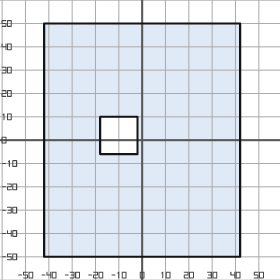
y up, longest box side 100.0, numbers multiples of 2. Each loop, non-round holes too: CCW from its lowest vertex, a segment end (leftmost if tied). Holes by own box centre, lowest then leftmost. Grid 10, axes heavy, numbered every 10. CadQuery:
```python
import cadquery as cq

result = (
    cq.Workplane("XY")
    .moveTo(-42.0, -50.0)
    .lineTo(42.0, -50.0)
    .lineTo(42.0, 50.0)
    .lineTo(-42.0, 50.0)
    .close()
    .moveTo(-18.0, -6.0)
    .lineTo(-2.0, -6.0)
    .lineTo(-2.0, 10.0)
    .lineTo(-18.0, 10.0)
    .close()
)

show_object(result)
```